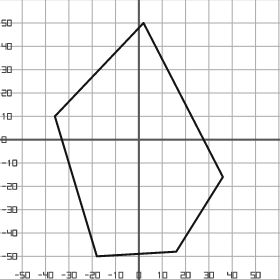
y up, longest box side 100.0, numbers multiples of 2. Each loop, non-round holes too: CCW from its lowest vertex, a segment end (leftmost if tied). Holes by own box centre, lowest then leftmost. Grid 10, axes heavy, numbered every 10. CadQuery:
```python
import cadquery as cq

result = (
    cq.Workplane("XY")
    .moveTo(-18.0, -50.0)
    .lineTo(16.0, -48.0)
    .lineTo(36.0, -16.0)
    .lineTo(2.0, 50.0)
    .lineTo(-36.0, 10.0)
    .close()
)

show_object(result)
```